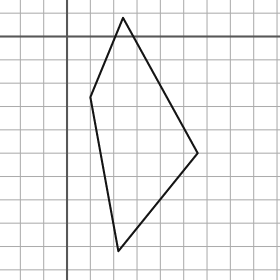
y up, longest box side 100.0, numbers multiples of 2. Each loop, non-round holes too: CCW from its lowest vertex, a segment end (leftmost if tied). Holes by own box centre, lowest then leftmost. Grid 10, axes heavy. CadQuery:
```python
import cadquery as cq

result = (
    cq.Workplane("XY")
    .moveTo(22.0, -92.0)
    .lineTo(56.0, -50.0)
    .lineTo(24.0, 8.0)
    .lineTo(10.0, -26.0)
    .close()
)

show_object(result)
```